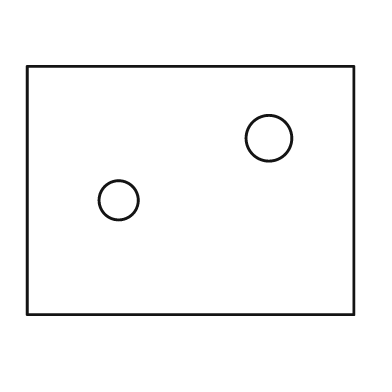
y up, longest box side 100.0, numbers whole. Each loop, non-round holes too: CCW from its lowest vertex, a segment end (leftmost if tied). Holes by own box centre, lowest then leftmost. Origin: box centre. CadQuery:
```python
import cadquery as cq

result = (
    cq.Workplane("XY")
    .moveTo(-50.0, -38.0)
    .lineTo(50.0, -38.0)
    .lineTo(50.0, 38.0)
    .lineTo(-50.0, 38.0)
    .close()
    .moveTo(-22.0, -3.0)
    .circle(6.0)
    .moveTo(24.0, 16.0)
    .circle(7.0)
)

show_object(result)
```